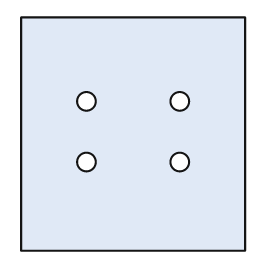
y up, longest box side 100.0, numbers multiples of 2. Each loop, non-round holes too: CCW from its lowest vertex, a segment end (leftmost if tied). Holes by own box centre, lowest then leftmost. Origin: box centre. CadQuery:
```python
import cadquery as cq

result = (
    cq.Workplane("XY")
    .moveTo(-48.0, -50.0)
    .lineTo(48.0, -50.0)
    .lineTo(48.0, 50.0)
    .lineTo(-48.0, 50.0)
    .close()
    .moveTo(-20.0, -12.0)
    .circle(4.0)
    .moveTo(20.0, -12.0)
    .circle(4.0)
    .moveTo(-20.0, 14.0)
    .circle(4.0)
    .moveTo(20.0, 14.0)
    .circle(4.0)
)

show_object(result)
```